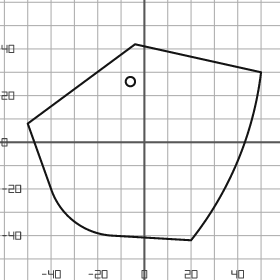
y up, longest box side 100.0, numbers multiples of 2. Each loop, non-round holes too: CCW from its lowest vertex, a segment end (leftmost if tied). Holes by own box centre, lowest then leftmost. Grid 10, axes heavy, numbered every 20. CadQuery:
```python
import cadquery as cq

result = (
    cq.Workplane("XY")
    .moveTo(20.0, -42.0)
    .threePointArc((40.0, -8.0), (50.0, 30.0))
    .lineTo(-4.0, 42.0)
    .lineTo(-50.0, 8.0)
    .lineTo(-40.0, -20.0)
    .threePointArc((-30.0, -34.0), (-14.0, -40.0))
    .close()
    .moveTo(-6.0, 26.0)
    .circle(2.0)
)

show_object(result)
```